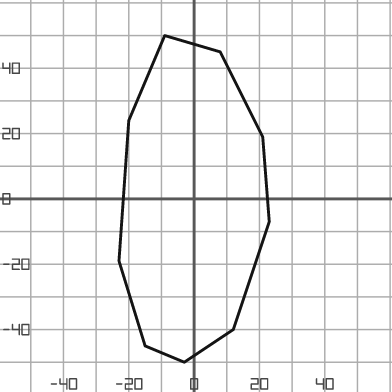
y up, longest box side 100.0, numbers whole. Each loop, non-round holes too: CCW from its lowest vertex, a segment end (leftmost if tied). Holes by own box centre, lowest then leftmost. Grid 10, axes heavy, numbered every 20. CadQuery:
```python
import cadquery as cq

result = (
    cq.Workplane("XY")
    .moveTo(-3.0, -50.0)
    .lineTo(12.0, -40.0)
    .lineTo(23.0, -7.0)
    .lineTo(21.0, 19.0)
    .lineTo(8.0, 45.0)
    .lineTo(-9.0, 50.0)
    .lineTo(-20.0, 24.0)
    .lineTo(-23.0, -19.0)
    .lineTo(-15.0, -45.0)
    .close()
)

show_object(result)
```